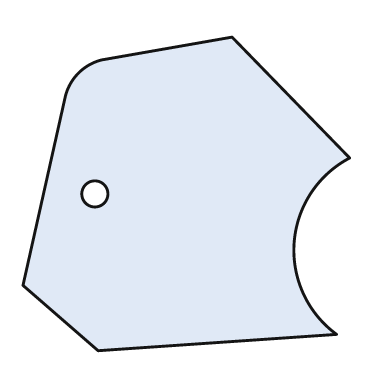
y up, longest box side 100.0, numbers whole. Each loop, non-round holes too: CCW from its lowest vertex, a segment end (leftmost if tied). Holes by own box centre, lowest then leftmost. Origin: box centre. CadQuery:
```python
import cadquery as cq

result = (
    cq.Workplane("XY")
    .moveTo(-27.0, -48.0)
    .lineTo(46.0, -43.0)
    .threePointArc((33.0, -15.0), (50.0, 11.0))
    .lineTo(14.0, 48.0)
    .lineTo(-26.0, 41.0)
    .threePointArc((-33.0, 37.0), (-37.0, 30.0))
    .lineTo(-50.0, -28.0)
    .close()
    .moveTo(-28.0, 0.0)
    .circle(4.0)
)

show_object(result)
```